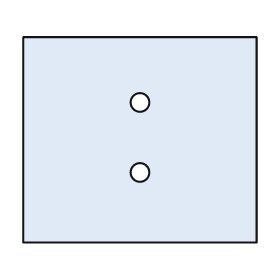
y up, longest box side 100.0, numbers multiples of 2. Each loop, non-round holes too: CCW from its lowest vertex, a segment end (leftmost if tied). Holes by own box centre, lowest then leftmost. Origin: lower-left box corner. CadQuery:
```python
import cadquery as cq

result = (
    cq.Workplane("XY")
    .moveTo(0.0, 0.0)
    .lineTo(100.0, 0.0)
    .lineTo(100.0, 88.0)
    .lineTo(0.0, 88.0)
    .close()
    .moveTo(50.0, 30.0)
    .circle(4.0)
    .moveTo(50.0, 60.0)
    .circle(4.0)
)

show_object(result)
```